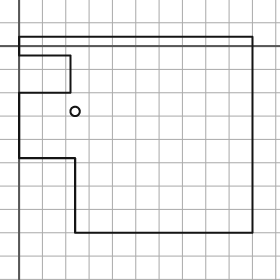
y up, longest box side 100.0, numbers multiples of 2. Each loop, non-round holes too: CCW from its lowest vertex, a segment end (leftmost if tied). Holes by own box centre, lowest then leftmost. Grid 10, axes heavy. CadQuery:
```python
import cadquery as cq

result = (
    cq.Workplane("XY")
    .moveTo(24.0, -80.0)
    .lineTo(100.0, -80.0)
    .lineTo(100.0, 4.0)
    .lineTo(0.0, 4.0)
    .lineTo(0.0, -4.0)
    .lineTo(22.0, -4.0)
    .lineTo(22.0, -20.0)
    .lineTo(0.0, -20.0)
    .lineTo(0.0, -48.0)
    .lineTo(24.0, -48.0)
    .close()
    .moveTo(24.0, -28.0)
    .circle(2.0)
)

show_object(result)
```